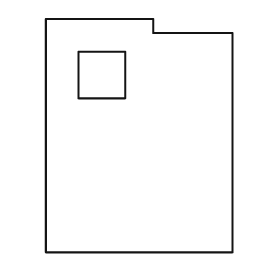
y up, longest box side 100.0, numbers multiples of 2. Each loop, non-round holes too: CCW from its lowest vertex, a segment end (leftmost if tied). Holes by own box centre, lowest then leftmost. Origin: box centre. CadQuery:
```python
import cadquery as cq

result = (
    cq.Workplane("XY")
    .moveTo(-40.0, -50.0)
    .lineTo(40.0, -50.0)
    .lineTo(40.0, 44.0)
    .lineTo(6.0, 44.0)
    .lineTo(6.0, 50.0)
    .lineTo(-40.0, 50.0)
    .close()
    .moveTo(-26.0, 16.0)
    .lineTo(-6.0, 16.0)
    .lineTo(-6.0, 36.0)
    .lineTo(-26.0, 36.0)
    .close()
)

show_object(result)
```